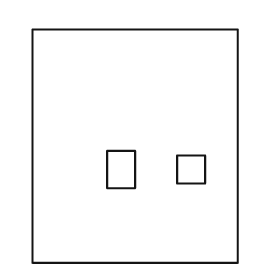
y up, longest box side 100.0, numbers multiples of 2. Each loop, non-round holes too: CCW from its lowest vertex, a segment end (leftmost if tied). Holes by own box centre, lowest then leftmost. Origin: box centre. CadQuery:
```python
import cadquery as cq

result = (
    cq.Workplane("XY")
    .moveTo(-44.0, -50.0)
    .lineTo(44.0, -50.0)
    .lineTo(44.0, 50.0)
    .lineTo(-44.0, 50.0)
    .close()
    .moveTo(-12.0, -18.0)
    .lineTo(0.0, -18.0)
    .lineTo(0.0, -2.0)
    .lineTo(-12.0, -2.0)
    .close()
    .moveTo(18.0, -16.0)
    .lineTo(30.0, -16.0)
    .lineTo(30.0, -4.0)
    .lineTo(18.0, -4.0)
    .close()
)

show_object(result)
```